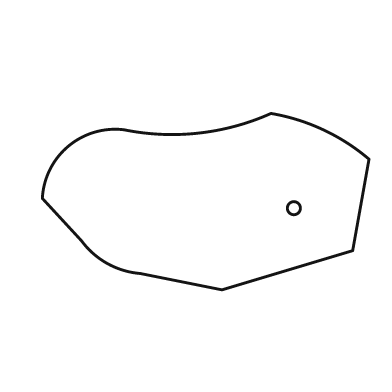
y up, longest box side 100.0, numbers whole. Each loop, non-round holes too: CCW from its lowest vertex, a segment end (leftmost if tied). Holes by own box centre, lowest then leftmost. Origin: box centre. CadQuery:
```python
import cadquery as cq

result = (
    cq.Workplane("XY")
    .moveTo(5.0, -27.0)
    .lineTo(45.0, -15.0)
    .lineTo(50.0, 13.0)
    .threePointArc((36.0, 22.0), (20.0, 27.0))
    .threePointArc((-2.0, 21.0), (-25.0, 22.0))
    .threePointArc((-42.0, 17.0), (-50.0, 1.0))
    .lineTo(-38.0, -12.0)
    .threePointArc((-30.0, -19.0), (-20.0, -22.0))
    .close()
    .moveTo(27.0, -2.0)
    .circle(2.0)
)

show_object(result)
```